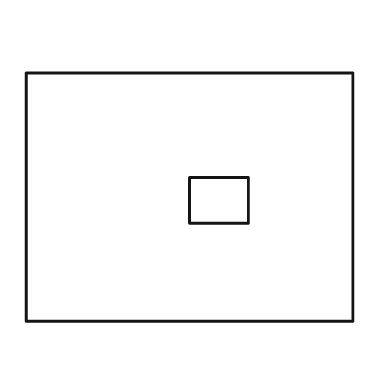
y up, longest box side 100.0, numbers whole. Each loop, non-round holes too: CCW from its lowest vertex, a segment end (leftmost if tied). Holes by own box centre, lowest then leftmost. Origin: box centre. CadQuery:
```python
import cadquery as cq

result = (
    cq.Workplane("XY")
    .moveTo(-50.0, -38.0)
    .lineTo(50.0, -38.0)
    .lineTo(50.0, 38.0)
    .lineTo(-50.0, 38.0)
    .close()
    .moveTo(0.0, -8.0)
    .lineTo(18.0, -8.0)
    .lineTo(18.0, 6.0)
    .lineTo(0.0, 6.0)
    .close()
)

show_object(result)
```